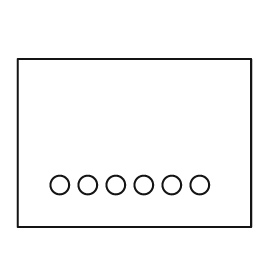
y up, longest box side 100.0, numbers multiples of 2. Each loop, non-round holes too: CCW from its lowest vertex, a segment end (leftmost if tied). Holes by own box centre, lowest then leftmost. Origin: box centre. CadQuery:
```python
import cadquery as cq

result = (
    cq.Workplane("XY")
    .moveTo(-50.0, -36.0)
    .lineTo(50.0, -36.0)
    .lineTo(50.0, 36.0)
    .lineTo(-50.0, 36.0)
    .close()
    .moveTo(-32.0, -18.0)
    .circle(4.0)
    .moveTo(-20.0, -18.0)
    .circle(4.0)
    .moveTo(-8.0, -18.0)
    .circle(4.0)
    .moveTo(4.0, -18.0)
    .circle(4.0)
    .moveTo(16.0, -18.0)
    .circle(4.0)
    .moveTo(28.0, -18.0)
    .circle(4.0)
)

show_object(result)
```